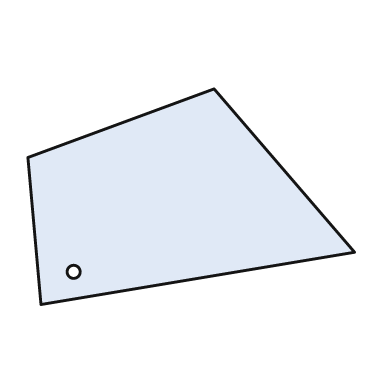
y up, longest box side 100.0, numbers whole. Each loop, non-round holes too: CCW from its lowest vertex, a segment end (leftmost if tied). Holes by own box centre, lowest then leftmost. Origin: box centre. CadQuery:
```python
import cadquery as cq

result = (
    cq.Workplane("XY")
    .moveTo(-46.0, -33.0)
    .lineTo(50.0, -17.0)
    .lineTo(7.0, 33.0)
    .lineTo(-50.0, 12.0)
    .close()
    .moveTo(-36.0, -23.0)
    .circle(2.0)
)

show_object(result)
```